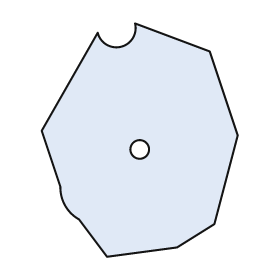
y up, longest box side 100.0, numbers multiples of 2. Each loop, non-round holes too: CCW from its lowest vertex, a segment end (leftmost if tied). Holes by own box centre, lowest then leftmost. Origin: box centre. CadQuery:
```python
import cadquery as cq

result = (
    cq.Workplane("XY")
    .moveTo(-14.0, -50.0)
    .lineTo(16.0, -46.0)
    .lineTo(32.0, -36.0)
    .lineTo(42.0, 2.0)
    .lineTo(30.0, 38.0)
    .lineTo(-2.0, 50.0)
    .threePointArc((-8.0, 40.0), (-18.0, 46.0))
    .lineTo(-42.0, 4.0)
    .lineTo(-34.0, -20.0)
    .threePointArc((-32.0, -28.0), (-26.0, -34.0))
    .close()
    .moveTo(0.0, -4.0)
    .circle(4.0)
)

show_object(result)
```